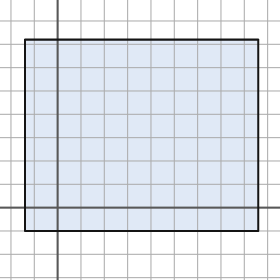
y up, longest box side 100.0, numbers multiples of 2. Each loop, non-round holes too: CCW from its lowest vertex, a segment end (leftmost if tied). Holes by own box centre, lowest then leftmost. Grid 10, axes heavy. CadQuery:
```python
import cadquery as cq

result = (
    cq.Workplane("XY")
    .moveTo(-14.0, -10.0)
    .lineTo(86.0, -10.0)
    .lineTo(86.0, 72.0)
    .lineTo(-14.0, 72.0)
    .close()
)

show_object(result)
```